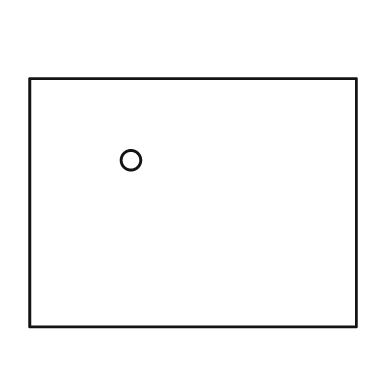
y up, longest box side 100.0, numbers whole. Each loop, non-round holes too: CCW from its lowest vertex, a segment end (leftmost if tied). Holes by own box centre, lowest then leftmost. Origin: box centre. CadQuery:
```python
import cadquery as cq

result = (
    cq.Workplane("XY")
    .moveTo(-50.0, -38.0)
    .lineTo(50.0, -38.0)
    .lineTo(50.0, 38.0)
    .lineTo(-50.0, 38.0)
    .close()
    .moveTo(-19.0, 13.0)
    .circle(3.0)
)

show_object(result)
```